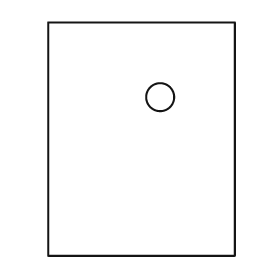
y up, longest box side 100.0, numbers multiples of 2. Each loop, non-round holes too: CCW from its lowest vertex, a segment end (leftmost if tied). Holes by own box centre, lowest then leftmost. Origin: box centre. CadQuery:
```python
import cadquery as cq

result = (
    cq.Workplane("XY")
    .moveTo(-40.0, -50.0)
    .lineTo(40.0, -50.0)
    .lineTo(40.0, 50.0)
    .lineTo(-40.0, 50.0)
    .close()
    .moveTo(8.0, 18.0)
    .circle(6.0)
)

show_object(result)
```